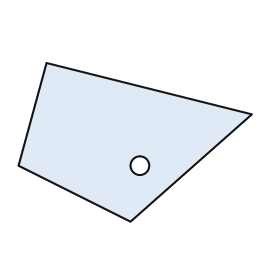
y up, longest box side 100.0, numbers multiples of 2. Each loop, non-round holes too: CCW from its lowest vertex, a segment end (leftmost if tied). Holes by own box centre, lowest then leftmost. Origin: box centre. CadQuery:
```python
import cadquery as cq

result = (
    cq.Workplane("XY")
    .moveTo(-2.0, -34.0)
    .lineTo(50.0, 12.0)
    .lineTo(-38.0, 34.0)
    .lineTo(-50.0, -10.0)
    .close()
    .moveTo(2.0, -10.0)
    .circle(4.0)
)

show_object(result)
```